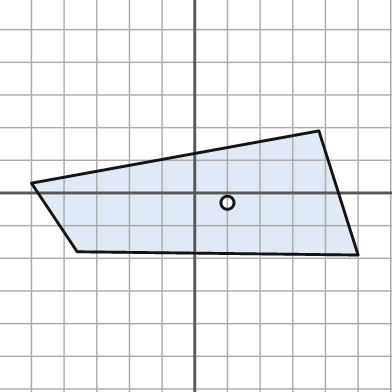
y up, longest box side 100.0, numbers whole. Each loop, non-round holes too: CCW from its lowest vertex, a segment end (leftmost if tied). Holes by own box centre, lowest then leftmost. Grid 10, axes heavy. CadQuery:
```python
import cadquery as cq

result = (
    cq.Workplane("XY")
    .moveTo(50.0, -19.0)
    .lineTo(38.0, 19.0)
    .lineTo(-50.0, 3.0)
    .lineTo(-36.0, -18.0)
    .close()
    .moveTo(10.0, -3.0)
    .circle(2.0)
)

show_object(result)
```